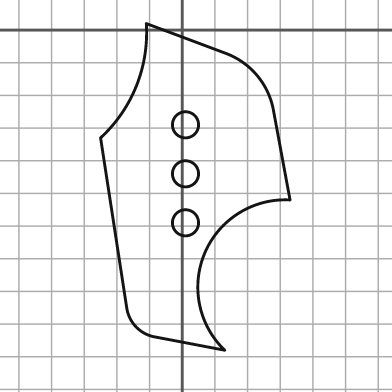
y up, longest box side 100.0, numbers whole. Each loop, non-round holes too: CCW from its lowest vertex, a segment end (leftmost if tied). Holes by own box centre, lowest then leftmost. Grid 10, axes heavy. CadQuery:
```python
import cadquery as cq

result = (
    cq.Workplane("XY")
    .moveTo(13.0, -98.0)
    .threePointArc((7.0, -68.0), (33.0, -52.0))
    .lineTo(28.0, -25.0)
    .threePointArc((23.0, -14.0), (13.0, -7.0))
    .lineTo(-11.0, 2.0)
    .threePointArc((-14.0, -17.0), (-25.0, -33.0))
    .lineTo(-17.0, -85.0)
    .threePointArc((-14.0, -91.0), (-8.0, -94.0))
    .close()
    .moveTo(1.0, -59.0)
    .circle(4.0)
    .moveTo(1.0, -44.0)
    .circle(4.0)
    .moveTo(1.0, -29.0)
    .circle(4.0)
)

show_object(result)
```